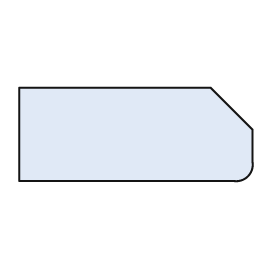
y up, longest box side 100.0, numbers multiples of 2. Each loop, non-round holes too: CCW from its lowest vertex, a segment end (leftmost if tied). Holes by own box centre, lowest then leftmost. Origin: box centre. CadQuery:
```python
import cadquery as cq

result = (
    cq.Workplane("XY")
    .moveTo(-50.0, -20.0)
    .lineTo(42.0, -20.0)
    .threePointArc((48.0, -18.0), (50.0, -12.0))
    .lineTo(50.0, 2.0)
    .lineTo(32.0, 20.0)
    .lineTo(-50.0, 20.0)
    .close()
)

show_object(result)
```